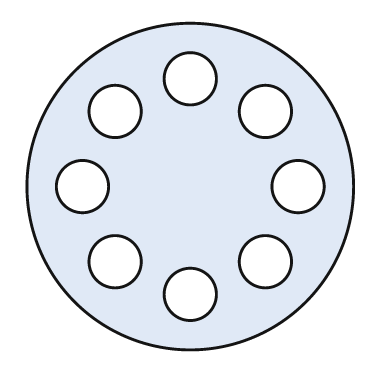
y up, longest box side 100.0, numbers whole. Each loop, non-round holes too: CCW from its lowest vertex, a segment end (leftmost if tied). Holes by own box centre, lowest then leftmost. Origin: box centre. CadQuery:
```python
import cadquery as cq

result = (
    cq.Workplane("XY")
    .moveTo(0.0, 0.0)
    .circle(50.0)
    .moveTo(0.0, -33.0)
    .circle(8.0)
    .moveTo(-23.0, -23.0)
    .circle(8.0)
    .moveTo(23.0, -23.0)
    .circle(8.0)
    .moveTo(-33.0, 0.0)
    .circle(8.0)
    .moveTo(33.0, 0.0)
    .circle(8.0)
    .moveTo(-23.0, 23.0)
    .circle(8.0)
    .moveTo(23.0, 23.0)
    .circle(8.0)
    .moveTo(0.0, 33.0)
    .circle(8.0)
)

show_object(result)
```